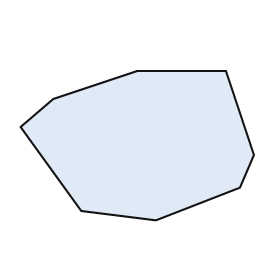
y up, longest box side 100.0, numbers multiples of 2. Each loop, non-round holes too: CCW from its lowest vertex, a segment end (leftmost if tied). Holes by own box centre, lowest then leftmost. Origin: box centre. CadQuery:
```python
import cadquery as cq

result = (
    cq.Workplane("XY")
    .moveTo(8.0, -32.0)
    .lineTo(44.0, -18.0)
    .lineTo(50.0, -4.0)
    .lineTo(38.0, 32.0)
    .lineTo(0.0, 32.0)
    .lineTo(-36.0, 20.0)
    .lineTo(-50.0, 8.0)
    .lineTo(-24.0, -28.0)
    .close()
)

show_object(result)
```